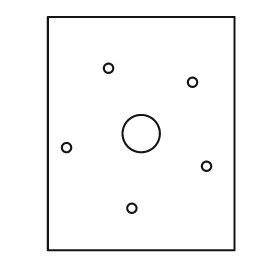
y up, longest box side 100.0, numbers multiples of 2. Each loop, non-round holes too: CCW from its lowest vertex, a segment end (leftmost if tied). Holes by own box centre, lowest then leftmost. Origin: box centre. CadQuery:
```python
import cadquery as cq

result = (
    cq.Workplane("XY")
    .moveTo(-40.0, -50.0)
    .lineTo(40.0, -50.0)
    .lineTo(40.0, 50.0)
    .lineTo(-40.0, 50.0)
    .close()
    .moveTo(-4.0, -32.0)
    .circle(2.0)
    .moveTo(28.0, -14.0)
    .circle(2.0)
    .moveTo(-32.0, -6.0)
    .circle(2.0)
    .moveTo(0.0, 0.0)
    .circle(8.0)
    .moveTo(22.0, 22.0)
    .circle(2.0)
    .moveTo(-14.0, 28.0)
    .circle(2.0)
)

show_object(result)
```